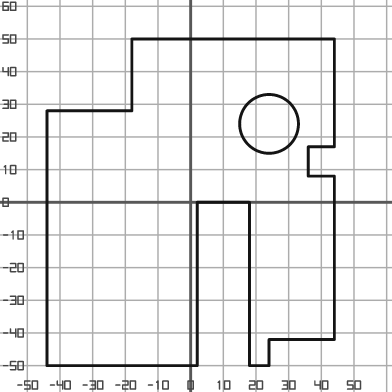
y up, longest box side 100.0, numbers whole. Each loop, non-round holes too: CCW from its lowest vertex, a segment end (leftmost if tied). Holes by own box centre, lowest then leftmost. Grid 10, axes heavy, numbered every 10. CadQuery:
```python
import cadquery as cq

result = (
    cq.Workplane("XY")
    .moveTo(-44.0, -50.0)
    .lineTo(2.0, -50.0)
    .lineTo(2.0, 0.0)
    .lineTo(18.0, 0.0)
    .lineTo(18.0, -50.0)
    .lineTo(24.0, -50.0)
    .lineTo(24.0, -42.0)
    .lineTo(44.0, -42.0)
    .lineTo(44.0, 8.0)
    .lineTo(36.0, 8.0)
    .lineTo(36.0, 17.0)
    .lineTo(44.0, 17.0)
    .lineTo(44.0, 50.0)
    .lineTo(-18.0, 50.0)
    .lineTo(-18.0, 28.0)
    .lineTo(-44.0, 28.0)
    .close()
    .moveTo(24.0, 24.0)
    .circle(9.0)
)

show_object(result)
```